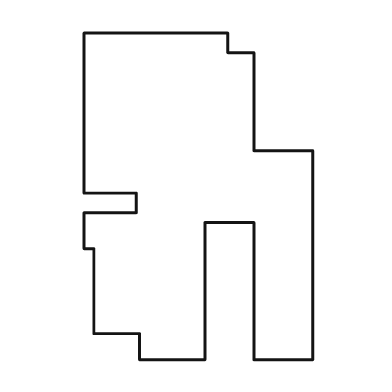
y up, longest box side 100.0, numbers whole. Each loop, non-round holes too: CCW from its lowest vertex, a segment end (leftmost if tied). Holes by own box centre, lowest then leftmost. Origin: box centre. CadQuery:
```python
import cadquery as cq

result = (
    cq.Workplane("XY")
    .moveTo(-18.0, -50.0)
    .lineTo(2.0, -50.0)
    .lineTo(2.0, -8.0)
    .lineTo(17.0, -8.0)
    .lineTo(17.0, -50.0)
    .lineTo(35.0, -50.0)
    .lineTo(35.0, 14.0)
    .lineTo(17.0, 14.0)
    .lineTo(17.0, 44.0)
    .lineTo(9.0, 44.0)
    .lineTo(9.0, 50.0)
    .lineTo(-35.0, 50.0)
    .lineTo(-35.0, 1.0)
    .lineTo(-19.0, 1.0)
    .lineTo(-19.0, -5.0)
    .lineTo(-35.0, -5.0)
    .lineTo(-35.0, -16.0)
    .lineTo(-32.0, -16.0)
    .lineTo(-32.0, -42.0)
    .lineTo(-18.0, -42.0)
    .close()
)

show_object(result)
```